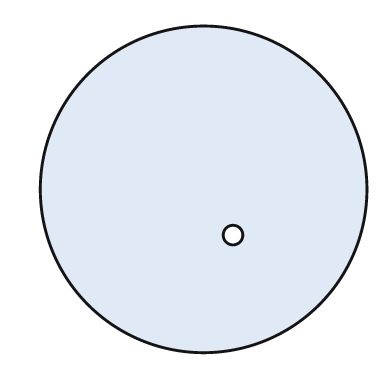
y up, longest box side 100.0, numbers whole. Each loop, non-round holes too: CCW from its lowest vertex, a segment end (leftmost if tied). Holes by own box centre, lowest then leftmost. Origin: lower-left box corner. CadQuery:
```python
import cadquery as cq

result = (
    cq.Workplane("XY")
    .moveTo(50.0, 50.0)
    .circle(50.0)
    .moveTo(59.0, 36.0)
    .circle(3.0)
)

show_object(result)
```